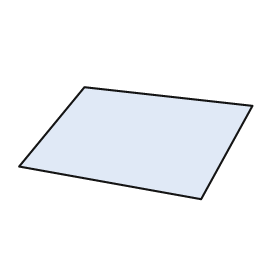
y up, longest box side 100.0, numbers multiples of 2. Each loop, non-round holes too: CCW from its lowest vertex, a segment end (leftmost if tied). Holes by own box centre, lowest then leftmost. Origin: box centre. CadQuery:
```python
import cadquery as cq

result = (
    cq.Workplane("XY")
    .moveTo(28.0, -24.0)
    .lineTo(50.0, 16.0)
    .lineTo(-22.0, 24.0)
    .lineTo(-50.0, -10.0)
    .close()
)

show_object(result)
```